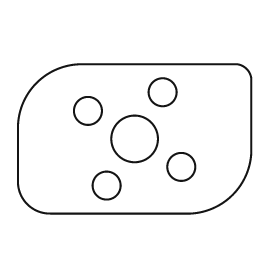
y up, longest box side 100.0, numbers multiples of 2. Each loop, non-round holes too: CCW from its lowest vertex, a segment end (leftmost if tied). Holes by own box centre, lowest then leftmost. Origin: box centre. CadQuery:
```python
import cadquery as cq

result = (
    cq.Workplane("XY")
    .moveTo(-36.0, -32.0)
    .lineTo(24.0, -32.0)
    .threePointArc((42.0, -24.0), (50.0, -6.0))
    .lineTo(50.0, 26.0)
    .threePointArc((48.0, 30.0), (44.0, 32.0))
    .lineTo(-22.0, 32.0)
    .threePointArc((-42.0, 24.0), (-50.0, 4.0))
    .lineTo(-50.0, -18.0)
    .threePointArc((-46.0, -28.0), (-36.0, -32.0))
    .close()
    .moveTo(-12.0, -20.0)
    .circle(6.0)
    .moveTo(20.0, -12.0)
    .circle(6.0)
    .moveTo(0.0, 0.0)
    .circle(10.0)
    .moveTo(-20.0, 12.0)
    .circle(6.0)
    .moveTo(12.0, 20.0)
    .circle(6.0)
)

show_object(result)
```